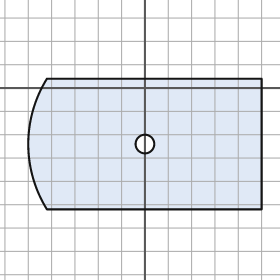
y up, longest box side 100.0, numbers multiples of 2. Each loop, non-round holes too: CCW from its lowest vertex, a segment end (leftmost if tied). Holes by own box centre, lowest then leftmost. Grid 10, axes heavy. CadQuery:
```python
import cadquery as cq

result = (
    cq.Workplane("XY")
    .moveTo(-42.0, -52.0)
    .lineTo(50.0, -52.0)
    .lineTo(50.0, 4.0)
    .lineTo(-42.0, 4.0)
    .threePointArc((-50.0, -24.0), (-42.0, -52.0))
    .close()
    .moveTo(0.0, -24.0)
    .circle(4.0)
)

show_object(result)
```